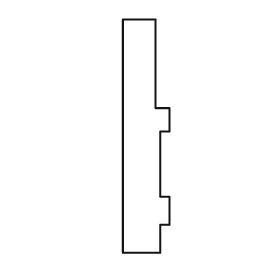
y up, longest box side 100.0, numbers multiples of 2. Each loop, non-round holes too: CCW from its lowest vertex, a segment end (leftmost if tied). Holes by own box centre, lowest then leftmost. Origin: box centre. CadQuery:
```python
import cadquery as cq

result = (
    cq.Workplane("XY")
    .moveTo(-10.0, -50.0)
    .lineTo(6.0, -50.0)
    .lineTo(6.0, -38.0)
    .lineTo(10.0, -38.0)
    .lineTo(10.0, -26.0)
    .lineTo(6.0, -26.0)
    .lineTo(6.0, 2.0)
    .lineTo(10.0, 2.0)
    .lineTo(10.0, 12.0)
    .lineTo(4.0, 12.0)
    .lineTo(4.0, 50.0)
    .lineTo(-10.0, 50.0)
    .close()
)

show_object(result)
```